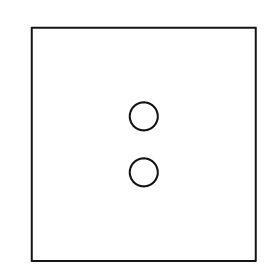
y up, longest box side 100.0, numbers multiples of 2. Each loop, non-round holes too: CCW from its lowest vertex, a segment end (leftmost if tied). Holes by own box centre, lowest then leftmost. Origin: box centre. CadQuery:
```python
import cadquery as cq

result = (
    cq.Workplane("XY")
    .moveTo(-48.0, -50.0)
    .lineTo(48.0, -50.0)
    .lineTo(48.0, 50.0)
    .lineTo(-48.0, 50.0)
    .close()
    .moveTo(0.0, -12.0)
    .circle(6.0)
    .moveTo(0.0, 12.0)
    .circle(6.0)
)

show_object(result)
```